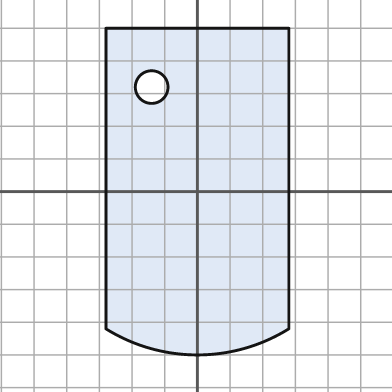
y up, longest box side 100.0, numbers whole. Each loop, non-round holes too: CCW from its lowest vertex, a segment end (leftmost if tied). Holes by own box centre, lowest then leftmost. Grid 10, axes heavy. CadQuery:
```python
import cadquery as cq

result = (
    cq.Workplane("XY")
    .moveTo(-28.0, -42.0)
    .threePointArc((0.0, -50.0), (28.0, -42.0))
    .lineTo(28.0, 50.0)
    .lineTo(-28.0, 50.0)
    .close()
    .moveTo(-14.0, 32.0)
    .circle(5.0)
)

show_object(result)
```